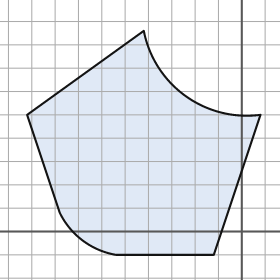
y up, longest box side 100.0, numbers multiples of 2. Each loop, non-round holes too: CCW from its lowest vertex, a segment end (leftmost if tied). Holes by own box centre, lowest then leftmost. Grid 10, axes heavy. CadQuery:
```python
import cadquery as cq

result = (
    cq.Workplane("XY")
    .moveTo(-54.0, -10.0)
    .lineTo(-12.0, -10.0)
    .lineTo(8.0, 50.0)
    .threePointArc((-24.0, 58.0), (-42.0, 86.0))
    .lineTo(-92.0, 50.0)
    .lineTo(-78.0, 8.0)
    .threePointArc((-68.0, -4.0), (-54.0, -10.0))
    .close()
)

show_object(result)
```